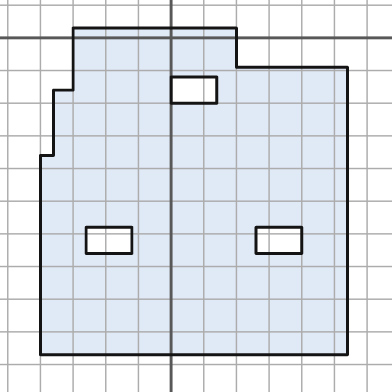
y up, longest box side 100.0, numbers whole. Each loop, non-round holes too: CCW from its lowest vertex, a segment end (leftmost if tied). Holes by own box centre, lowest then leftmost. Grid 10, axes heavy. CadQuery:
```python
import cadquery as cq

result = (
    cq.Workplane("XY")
    .moveTo(-40.0, -97.0)
    .lineTo(54.0, -97.0)
    .lineTo(54.0, -9.0)
    .lineTo(20.0, -9.0)
    .lineTo(20.0, 3.0)
    .lineTo(-30.0, 3.0)
    .lineTo(-30.0, -16.0)
    .lineTo(-36.0, -16.0)
    .lineTo(-36.0, -36.0)
    .lineTo(-40.0, -36.0)
    .close()
    .moveTo(-26.0, -66.0)
    .lineTo(-12.0, -66.0)
    .lineTo(-12.0, -58.0)
    .lineTo(-26.0, -58.0)
    .close()
    .moveTo(26.0, -66.0)
    .lineTo(40.0, -66.0)
    .lineTo(40.0, -58.0)
    .lineTo(26.0, -58.0)
    .close()
    .moveTo(0.0, -20.0)
    .lineTo(14.0, -20.0)
    .lineTo(14.0, -12.0)
    .lineTo(0.0, -12.0)
    .close()
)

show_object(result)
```